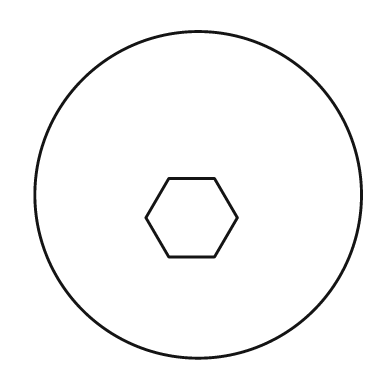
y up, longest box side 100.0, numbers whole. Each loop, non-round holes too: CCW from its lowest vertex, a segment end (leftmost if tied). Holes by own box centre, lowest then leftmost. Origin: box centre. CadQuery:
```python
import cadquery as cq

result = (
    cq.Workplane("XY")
    .moveTo(0.0, 0.0)
    .circle(50.0)
    .moveTo(-9.0, -19.0)
    .lineTo(5.0, -19.0)
    .lineTo(12.0, -7.0)
    .lineTo(5.0, 5.0)
    .lineTo(-9.0, 5.0)
    .lineTo(-16.0, -7.0)
    .close()
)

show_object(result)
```